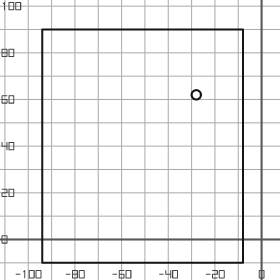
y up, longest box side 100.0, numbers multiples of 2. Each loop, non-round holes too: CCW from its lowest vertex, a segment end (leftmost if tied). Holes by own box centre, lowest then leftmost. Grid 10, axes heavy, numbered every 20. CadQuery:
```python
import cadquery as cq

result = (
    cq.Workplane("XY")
    .moveTo(-94.0, -10.0)
    .lineTo(-8.0, -10.0)
    .lineTo(-8.0, 90.0)
    .lineTo(-94.0, 90.0)
    .close()
    .moveTo(-28.0, 62.0)
    .circle(2.0)
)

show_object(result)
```